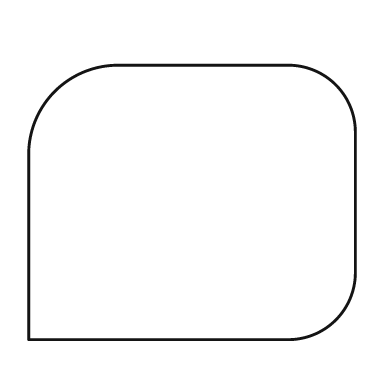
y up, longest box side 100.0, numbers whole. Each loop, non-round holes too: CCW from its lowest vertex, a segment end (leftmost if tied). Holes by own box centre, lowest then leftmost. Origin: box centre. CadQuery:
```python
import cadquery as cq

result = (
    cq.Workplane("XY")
    .moveTo(-50.0, -42.0)
    .lineTo(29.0, -42.0)
    .threePointArc((44.0, -36.0), (50.0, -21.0))
    .lineTo(50.0, 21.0)
    .threePointArc((44.0, 36.0), (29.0, 42.0))
    .lineTo(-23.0, 42.0)
    .threePointArc((-42.0, 34.0), (-50.0, 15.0))
    .close()
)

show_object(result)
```